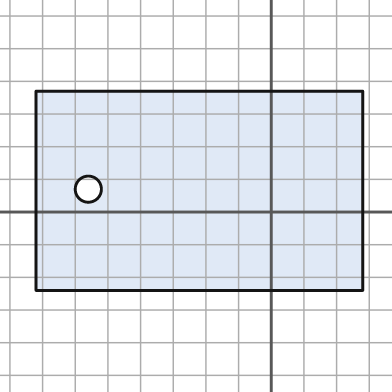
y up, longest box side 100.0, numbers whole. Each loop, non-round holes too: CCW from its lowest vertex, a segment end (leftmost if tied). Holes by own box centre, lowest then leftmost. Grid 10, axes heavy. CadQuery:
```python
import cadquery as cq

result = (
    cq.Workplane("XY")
    .moveTo(-72.0, -24.0)
    .lineTo(28.0, -24.0)
    .lineTo(28.0, 37.0)
    .lineTo(-72.0, 37.0)
    .close()
    .moveTo(-56.0, 7.0)
    .circle(4.0)
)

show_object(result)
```